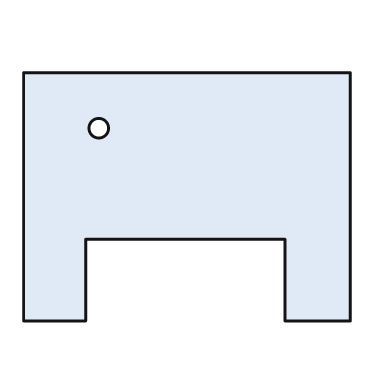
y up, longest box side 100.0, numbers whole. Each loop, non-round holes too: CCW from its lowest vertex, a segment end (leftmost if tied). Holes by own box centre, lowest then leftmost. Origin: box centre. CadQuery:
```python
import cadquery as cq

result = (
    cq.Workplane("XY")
    .moveTo(-50.0, -38.0)
    .lineTo(-31.0, -38.0)
    .lineTo(-31.0, -13.0)
    .lineTo(30.0, -13.0)
    .lineTo(30.0, -38.0)
    .lineTo(50.0, -38.0)
    .lineTo(50.0, 38.0)
    .lineTo(-50.0, 38.0)
    .close()
    .moveTo(-27.0, 21.0)
    .circle(3.0)
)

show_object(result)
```